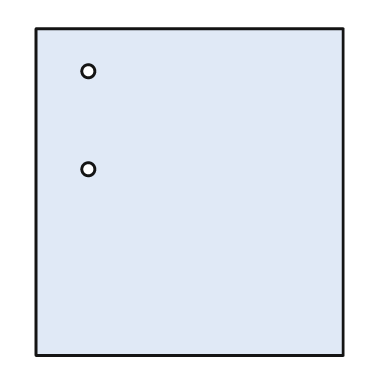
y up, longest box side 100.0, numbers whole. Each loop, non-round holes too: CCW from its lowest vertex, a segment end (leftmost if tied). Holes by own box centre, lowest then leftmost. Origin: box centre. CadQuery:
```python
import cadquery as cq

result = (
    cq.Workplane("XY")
    .moveTo(-47.0, -50.0)
    .lineTo(47.0, -50.0)
    .lineTo(47.0, 50.0)
    .lineTo(-47.0, 50.0)
    .close()
    .moveTo(-31.0, 7.0)
    .circle(2.0)
    .moveTo(-31.0, 37.0)
    .circle(2.0)
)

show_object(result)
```